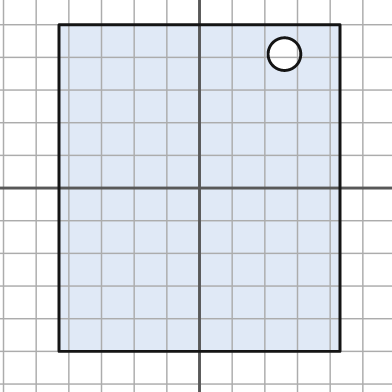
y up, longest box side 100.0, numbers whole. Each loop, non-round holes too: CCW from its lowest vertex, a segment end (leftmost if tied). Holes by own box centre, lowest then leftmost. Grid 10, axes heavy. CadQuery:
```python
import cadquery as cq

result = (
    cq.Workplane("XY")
    .moveTo(-43.0, -50.0)
    .lineTo(43.0, -50.0)
    .lineTo(43.0, 50.0)
    .lineTo(-43.0, 50.0)
    .close()
    .moveTo(26.0, 41.0)
    .circle(5.0)
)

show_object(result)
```